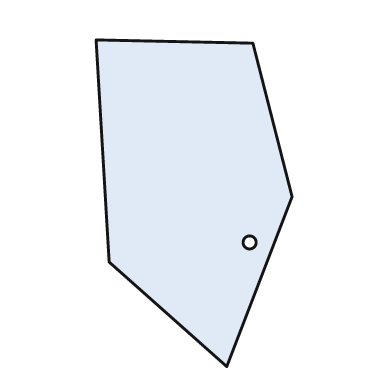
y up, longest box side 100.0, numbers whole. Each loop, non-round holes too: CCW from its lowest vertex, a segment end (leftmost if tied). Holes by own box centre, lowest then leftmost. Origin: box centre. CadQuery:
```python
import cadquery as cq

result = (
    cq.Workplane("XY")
    .moveTo(10.0, -50.0)
    .lineTo(30.0, 2.0)
    .lineTo(18.0, 49.0)
    .lineTo(-30.0, 50.0)
    .lineTo(-26.0, -18.0)
    .close()
    .moveTo(17.0, -12.0)
    .circle(2.0)
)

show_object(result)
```